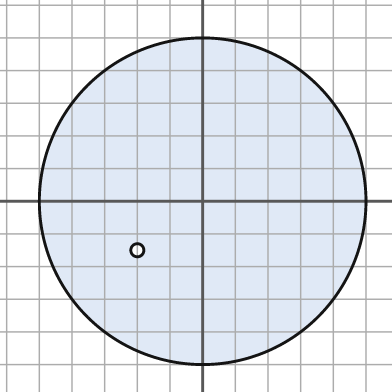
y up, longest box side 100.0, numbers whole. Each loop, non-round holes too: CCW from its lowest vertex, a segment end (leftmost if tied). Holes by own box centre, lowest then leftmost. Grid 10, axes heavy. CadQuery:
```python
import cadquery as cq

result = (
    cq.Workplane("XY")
    .moveTo(0.0, 0.0)
    .circle(50.0)
    .moveTo(-20.0, -15.0)
    .circle(2.0)
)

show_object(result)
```